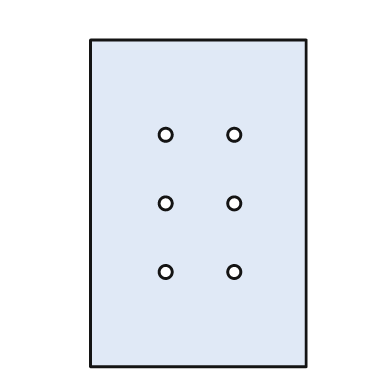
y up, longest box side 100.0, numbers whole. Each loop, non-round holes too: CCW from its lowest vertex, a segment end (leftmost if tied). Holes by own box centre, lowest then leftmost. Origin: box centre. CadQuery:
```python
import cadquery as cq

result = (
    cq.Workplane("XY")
    .moveTo(-33.0, -50.0)
    .lineTo(33.0, -50.0)
    .lineTo(33.0, 50.0)
    .lineTo(-33.0, 50.0)
    .close()
    .moveTo(-10.0, -21.0)
    .circle(2.0)
    .moveTo(11.0, -21.0)
    .circle(2.0)
    .moveTo(-10.0, 0.0)
    .circle(2.0)
    .moveTo(11.0, 0.0)
    .circle(2.0)
    .moveTo(-10.0, 21.0)
    .circle(2.0)
    .moveTo(11.0, 21.0)
    .circle(2.0)
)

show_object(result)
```